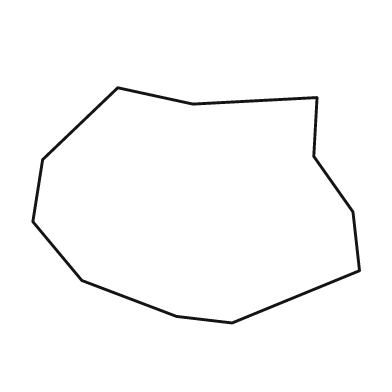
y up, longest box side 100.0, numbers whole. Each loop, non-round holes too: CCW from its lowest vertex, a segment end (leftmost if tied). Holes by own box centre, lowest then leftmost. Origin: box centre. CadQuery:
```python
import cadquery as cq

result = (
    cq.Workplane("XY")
    .moveTo(11.0, -36.0)
    .lineTo(50.0, -20.0)
    .lineTo(48.0, -2.0)
    .lineTo(36.0, 15.0)
    .lineTo(37.0, 33.0)
    .lineTo(-1.0, 31.0)
    .lineTo(-24.0, 36.0)
    .lineTo(-47.0, 14.0)
    .lineTo(-50.0, -5.0)
    .lineTo(-35.0, -23.0)
    .lineTo(-6.0, -34.0)
    .close()
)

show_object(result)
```